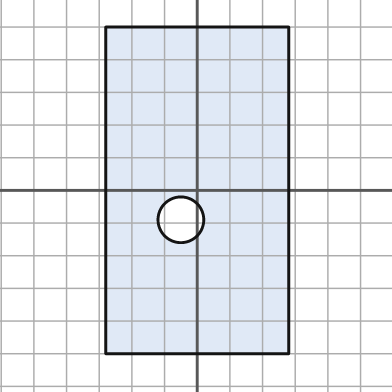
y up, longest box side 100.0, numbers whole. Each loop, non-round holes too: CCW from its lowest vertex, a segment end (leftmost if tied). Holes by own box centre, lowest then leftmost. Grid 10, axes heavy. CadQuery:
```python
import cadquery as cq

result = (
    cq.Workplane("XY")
    .moveTo(-28.0, -50.0)
    .lineTo(28.0, -50.0)
    .lineTo(28.0, 50.0)
    .lineTo(-28.0, 50.0)
    .close()
    .moveTo(-5.0, -9.0)
    .circle(7.0)
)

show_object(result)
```